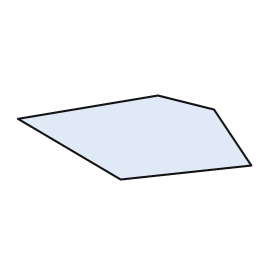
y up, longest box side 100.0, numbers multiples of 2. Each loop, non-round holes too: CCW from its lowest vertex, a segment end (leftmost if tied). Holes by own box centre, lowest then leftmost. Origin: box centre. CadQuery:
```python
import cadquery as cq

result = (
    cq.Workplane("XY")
    .moveTo(-6.0, -18.0)
    .lineTo(50.0, -12.0)
    .lineTo(34.0, 12.0)
    .lineTo(10.0, 18.0)
    .lineTo(-50.0, 8.0)
    .close()
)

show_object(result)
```